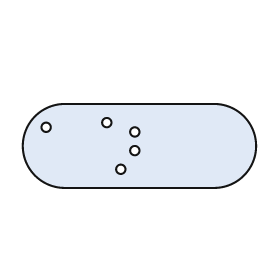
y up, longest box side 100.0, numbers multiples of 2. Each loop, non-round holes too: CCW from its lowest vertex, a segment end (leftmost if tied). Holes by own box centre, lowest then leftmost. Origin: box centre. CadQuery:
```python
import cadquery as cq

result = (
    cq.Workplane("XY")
    .moveTo(-32.0, -18.0)
    .lineTo(32.0, -18.0)
    .threePointArc((50.0, 0.0), (32.0, 18.0))
    .lineTo(-32.0, 18.0)
    .threePointArc((-50.0, 0.0), (-32.0, -18.0))
    .close()
    .moveTo(-8.0, -10.0)
    .circle(2.0)
    .moveTo(-2.0, -2.0)
    .circle(2.0)
    .moveTo(-2.0, 6.0)
    .circle(2.0)
    .moveTo(-40.0, 8.0)
    .circle(2.0)
    .moveTo(-14.0, 10.0)
    .circle(2.0)
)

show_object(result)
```